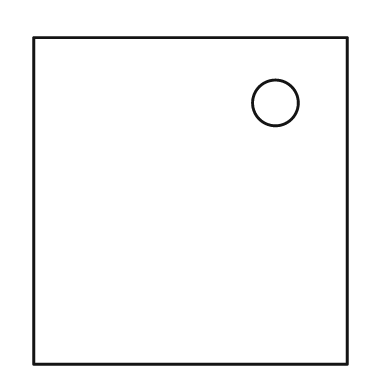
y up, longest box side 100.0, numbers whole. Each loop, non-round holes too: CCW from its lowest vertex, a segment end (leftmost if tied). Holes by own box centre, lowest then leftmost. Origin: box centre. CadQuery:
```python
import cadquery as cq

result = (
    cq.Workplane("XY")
    .moveTo(-48.0, -50.0)
    .lineTo(48.0, -50.0)
    .lineTo(48.0, 50.0)
    .lineTo(-48.0, 50.0)
    .close()
    .moveTo(26.0, 30.0)
    .circle(7.0)
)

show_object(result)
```